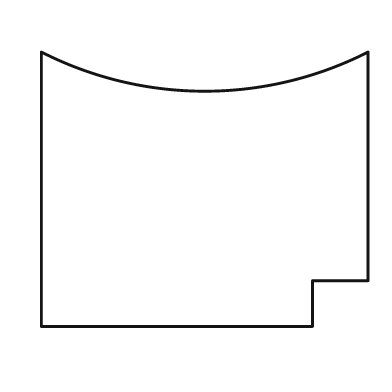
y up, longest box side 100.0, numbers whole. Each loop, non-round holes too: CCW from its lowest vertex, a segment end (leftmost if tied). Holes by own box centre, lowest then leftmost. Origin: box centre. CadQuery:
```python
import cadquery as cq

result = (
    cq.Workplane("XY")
    .moveTo(-50.0, -42.0)
    .lineTo(33.0, -42.0)
    .lineTo(33.0, -28.0)
    .lineTo(50.0, -28.0)
    .lineTo(50.0, 42.0)
    .threePointArc((0.0, 30.0), (-50.0, 42.0))
    .close()
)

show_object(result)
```